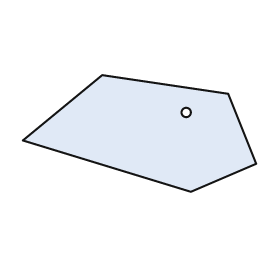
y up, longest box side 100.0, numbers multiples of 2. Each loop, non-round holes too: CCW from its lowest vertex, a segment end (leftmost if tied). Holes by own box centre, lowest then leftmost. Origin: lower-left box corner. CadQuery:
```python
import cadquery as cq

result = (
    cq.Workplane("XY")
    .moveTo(72.0, 0.0)
    .lineTo(100.0, 12.0)
    .lineTo(88.0, 42.0)
    .lineTo(34.0, 50.0)
    .lineTo(0.0, 22.0)
    .close()
    .moveTo(70.0, 34.0)
    .circle(2.0)
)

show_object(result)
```